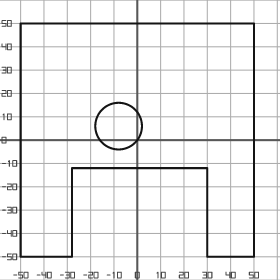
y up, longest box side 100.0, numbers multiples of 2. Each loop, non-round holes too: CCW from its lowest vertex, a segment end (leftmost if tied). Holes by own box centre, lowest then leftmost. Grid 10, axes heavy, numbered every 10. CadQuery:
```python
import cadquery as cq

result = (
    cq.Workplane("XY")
    .moveTo(-50.0, -50.0)
    .lineTo(-28.0, -50.0)
    .lineTo(-28.0, -12.0)
    .lineTo(30.0, -12.0)
    .lineTo(30.0, -50.0)
    .lineTo(50.0, -50.0)
    .lineTo(50.0, 50.0)
    .lineTo(-50.0, 50.0)
    .close()
    .moveTo(-8.0, 6.0)
    .circle(10.0)
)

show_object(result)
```